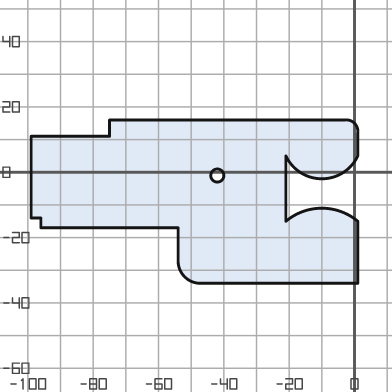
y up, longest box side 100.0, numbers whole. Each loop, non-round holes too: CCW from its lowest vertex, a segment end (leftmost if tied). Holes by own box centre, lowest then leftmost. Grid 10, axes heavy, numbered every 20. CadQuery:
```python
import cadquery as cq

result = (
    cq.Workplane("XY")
    .moveTo(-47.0, -34.0)
    .lineTo(1.0, -34.0)
    .lineTo(1.0, -15.0)
    .threePointArc((-10.0, -11.0), (-21.0, -15.0))
    .lineTo(-21.0, 5.0)
    .threePointArc((-10.0, -2.0), (1.0, 5.0))
    .lineTo(1.0, 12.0)
    .threePointArc((0.0, 15.0), (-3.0, 16.0))
    .lineTo(-75.0, 16.0)
    .lineTo(-75.0, 11.0)
    .lineTo(-99.0, 11.0)
    .lineTo(-99.0, -14.0)
    .lineTo(-96.0, -14.0)
    .lineTo(-96.0, -17.0)
    .lineTo(-54.0, -17.0)
    .lineTo(-54.0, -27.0)
    .threePointArc((-52.0, -32.0), (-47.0, -34.0))
    .close()
    .moveTo(-42.0, -1.0)
    .circle(2.0)
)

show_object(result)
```